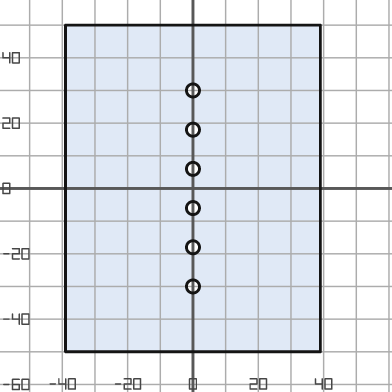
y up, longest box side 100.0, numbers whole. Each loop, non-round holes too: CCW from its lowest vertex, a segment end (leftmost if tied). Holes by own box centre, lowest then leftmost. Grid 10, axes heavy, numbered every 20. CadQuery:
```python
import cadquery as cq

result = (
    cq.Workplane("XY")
    .moveTo(-39.0, -50.0)
    .lineTo(39.0, -50.0)
    .lineTo(39.0, 50.0)
    .lineTo(-39.0, 50.0)
    .close()
    .moveTo(0.0, -30.0)
    .circle(2.0)
    .moveTo(0.0, -18.0)
    .circle(2.0)
    .moveTo(0.0, -6.0)
    .circle(2.0)
    .moveTo(0.0, 6.0)
    .circle(2.0)
    .moveTo(0.0, 18.0)
    .circle(2.0)
    .moveTo(0.0, 30.0)
    .circle(2.0)
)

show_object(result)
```